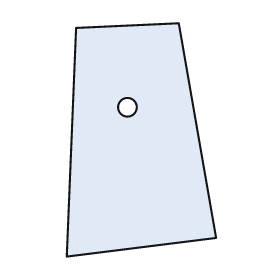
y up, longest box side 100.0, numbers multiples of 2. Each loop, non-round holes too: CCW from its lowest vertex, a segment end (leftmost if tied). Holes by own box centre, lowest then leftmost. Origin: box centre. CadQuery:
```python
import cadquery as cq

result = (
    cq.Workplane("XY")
    .moveTo(-32.0, -50.0)
    .lineTo(32.0, -42.0)
    .lineTo(16.0, 50.0)
    .lineTo(-28.0, 48.0)
    .close()
    .moveTo(-6.0, 14.0)
    .circle(4.0)
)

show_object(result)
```